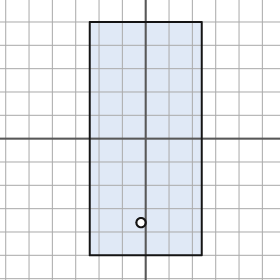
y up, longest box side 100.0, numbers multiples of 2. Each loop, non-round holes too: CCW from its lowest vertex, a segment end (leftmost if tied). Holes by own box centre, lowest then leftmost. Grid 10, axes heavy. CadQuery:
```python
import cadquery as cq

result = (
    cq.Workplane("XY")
    .moveTo(-24.0, -50.0)
    .lineTo(24.0, -50.0)
    .lineTo(24.0, 50.0)
    .lineTo(-24.0, 50.0)
    .close()
    .moveTo(-2.0, -36.0)
    .circle(2.0)
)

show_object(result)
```